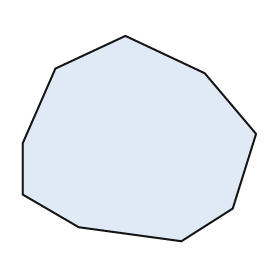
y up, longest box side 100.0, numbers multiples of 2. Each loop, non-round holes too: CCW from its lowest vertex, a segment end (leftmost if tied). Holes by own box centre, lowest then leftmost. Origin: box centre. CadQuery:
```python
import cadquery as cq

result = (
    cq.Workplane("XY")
    .moveTo(18.0, -44.0)
    .lineTo(40.0, -30.0)
    .lineTo(50.0, 2.0)
    .lineTo(28.0, 28.0)
    .lineTo(-6.0, 44.0)
    .lineTo(-36.0, 30.0)
    .lineTo(-50.0, -2.0)
    .lineTo(-50.0, -24.0)
    .lineTo(-26.0, -38.0)
    .close()
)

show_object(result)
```